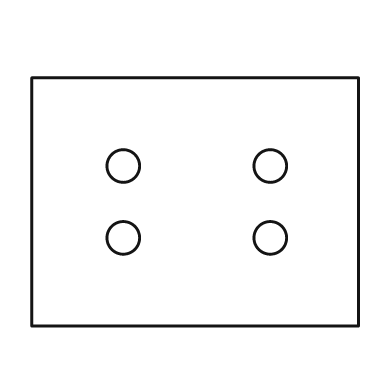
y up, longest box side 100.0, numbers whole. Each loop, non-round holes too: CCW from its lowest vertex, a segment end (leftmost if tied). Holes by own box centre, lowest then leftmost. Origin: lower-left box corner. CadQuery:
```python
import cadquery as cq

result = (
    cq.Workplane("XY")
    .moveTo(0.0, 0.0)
    .lineTo(100.0, 0.0)
    .lineTo(100.0, 76.0)
    .lineTo(0.0, 76.0)
    .close()
    .moveTo(28.0, 27.0)
    .circle(5.0)
    .moveTo(73.0, 27.0)
    .circle(5.0)
    .moveTo(28.0, 49.0)
    .circle(5.0)
    .moveTo(73.0, 49.0)
    .circle(5.0)
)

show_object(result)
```